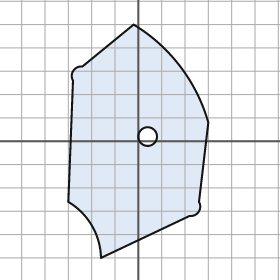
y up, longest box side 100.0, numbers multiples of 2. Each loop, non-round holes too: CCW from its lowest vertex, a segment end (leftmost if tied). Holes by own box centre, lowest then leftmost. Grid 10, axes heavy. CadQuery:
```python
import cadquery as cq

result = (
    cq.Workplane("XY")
    .moveTo(-16.0, -50.0)
    .lineTo(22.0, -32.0)
    .threePointArc((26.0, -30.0), (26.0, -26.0))
    .lineTo(30.0, 8.0)
    .threePointArc((18.0, 32.0), (-2.0, 50.0))
    .lineTo(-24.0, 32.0)
    .threePointArc((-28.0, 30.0), (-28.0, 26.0))
    .lineTo(-30.0, -26.0)
    .threePointArc((-20.0, -36.0), (-16.0, -50.0))
    .close()
    .moveTo(4.0, 2.0)
    .circle(4.0)
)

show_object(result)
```